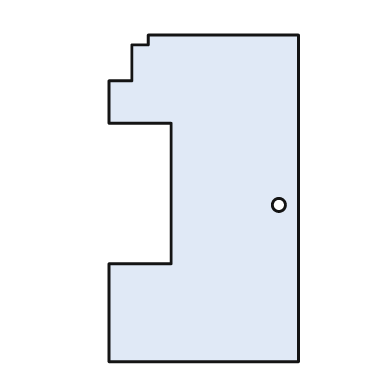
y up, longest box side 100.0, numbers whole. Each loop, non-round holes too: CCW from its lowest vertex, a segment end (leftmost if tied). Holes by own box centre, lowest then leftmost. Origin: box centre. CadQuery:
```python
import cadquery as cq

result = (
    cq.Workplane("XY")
    .moveTo(-29.0, -50.0)
    .lineTo(29.0, -50.0)
    .lineTo(29.0, 50.0)
    .lineTo(-17.0, 50.0)
    .lineTo(-17.0, 47.0)
    .lineTo(-22.0, 47.0)
    .lineTo(-22.0, 36.0)
    .lineTo(-29.0, 36.0)
    .lineTo(-29.0, 23.0)
    .lineTo(-10.0, 23.0)
    .lineTo(-10.0, -20.0)
    .lineTo(-29.0, -20.0)
    .close()
    .moveTo(23.0, -2.0)
    .circle(2.0)
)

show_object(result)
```